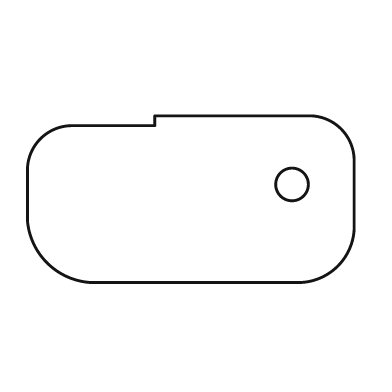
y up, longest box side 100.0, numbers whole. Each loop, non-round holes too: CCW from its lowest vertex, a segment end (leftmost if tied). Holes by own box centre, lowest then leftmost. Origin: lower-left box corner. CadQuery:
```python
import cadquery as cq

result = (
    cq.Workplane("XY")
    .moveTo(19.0, 0.0)
    .lineTo(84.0, 0.0)
    .threePointArc((95.0, 5.0), (100.0, 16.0))
    .lineTo(100.0, 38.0)
    .threePointArc((96.0, 47.0), (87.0, 51.0))
    .lineTo(39.0, 51.0)
    .lineTo(39.0, 48.0)
    .lineTo(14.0, 48.0)
    .threePointArc((4.0, 44.0), (0.0, 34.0))
    .lineTo(0.0, 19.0)
    .threePointArc((6.0, 6.0), (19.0, 0.0))
    .close()
    .moveTo(81.0, 30.0)
    .circle(5.0)
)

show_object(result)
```